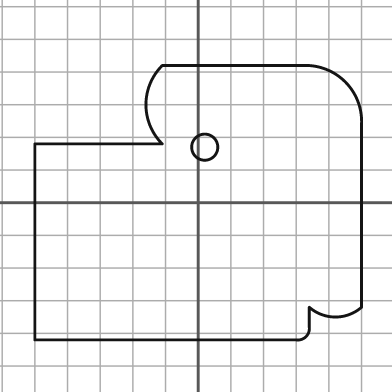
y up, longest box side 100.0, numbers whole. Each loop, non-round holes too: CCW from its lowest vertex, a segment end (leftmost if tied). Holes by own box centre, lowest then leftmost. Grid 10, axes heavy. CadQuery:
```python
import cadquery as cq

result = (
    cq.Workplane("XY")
    .moveTo(-50.0, -42.0)
    .lineTo(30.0, -42.0)
    .threePointArc((33.0, -41.0), (34.0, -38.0))
    .lineTo(34.0, -32.0)
    .threePointArc((42.0, -35.0), (50.0, -32.0))
    .lineTo(50.0, 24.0)
    .threePointArc((45.0, 37.0), (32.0, 42.0))
    .lineTo(-11.0, 42.0)
    .threePointArc((-16.0, 30.0), (-11.0, 18.0))
    .lineTo(-50.0, 18.0)
    .close()
    .moveTo(2.0, 17.0)
    .circle(4.0)
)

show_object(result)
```